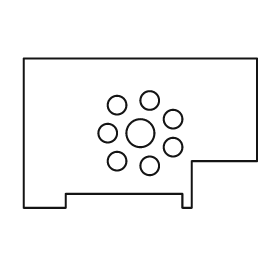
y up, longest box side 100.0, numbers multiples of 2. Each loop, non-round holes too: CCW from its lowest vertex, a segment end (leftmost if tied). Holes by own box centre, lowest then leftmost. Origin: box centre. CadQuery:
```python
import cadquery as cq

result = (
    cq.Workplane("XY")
    .moveTo(-50.0, -32.0)
    .lineTo(-32.0, -32.0)
    .lineTo(-32.0, -26.0)
    .lineTo(18.0, -26.0)
    .lineTo(18.0, -32.0)
    .lineTo(22.0, -32.0)
    .lineTo(22.0, -12.0)
    .lineTo(50.0, -12.0)
    .lineTo(50.0, 32.0)
    .lineTo(-50.0, 32.0)
    .close()
    .moveTo(4.0, -14.0)
    .circle(4.0)
    .moveTo(-10.0, -12.0)
    .circle(4.0)
    .moveTo(14.0, -6.0)
    .circle(4.0)
    .moveTo(-14.0, 0.0)
    .circle(4.0)
    .moveTo(0.0, 0.0)
    .circle(6.0)
    .moveTo(14.0, 6.0)
    .circle(4.0)
    .moveTo(-10.0, 12.0)
    .circle(4.0)
    .moveTo(4.0, 14.0)
    .circle(4.0)
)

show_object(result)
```